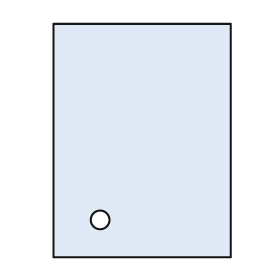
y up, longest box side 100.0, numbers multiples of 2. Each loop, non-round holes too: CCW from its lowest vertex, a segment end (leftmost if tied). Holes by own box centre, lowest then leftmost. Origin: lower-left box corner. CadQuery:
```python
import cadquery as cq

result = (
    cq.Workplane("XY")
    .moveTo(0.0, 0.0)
    .lineTo(76.0, 0.0)
    .lineTo(76.0, 100.0)
    .lineTo(0.0, 100.0)
    .close()
    .moveTo(20.0, 16.0)
    .circle(4.0)
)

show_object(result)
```